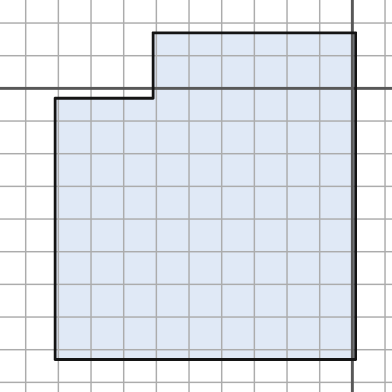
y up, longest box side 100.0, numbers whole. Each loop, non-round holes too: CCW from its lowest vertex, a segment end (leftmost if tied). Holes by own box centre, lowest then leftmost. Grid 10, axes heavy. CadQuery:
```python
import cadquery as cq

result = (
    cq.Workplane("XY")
    .moveTo(-91.0, -83.0)
    .lineTo(1.0, -83.0)
    .lineTo(1.0, 17.0)
    .lineTo(-61.0, 17.0)
    .lineTo(-61.0, -3.0)
    .lineTo(-91.0, -3.0)
    .close()
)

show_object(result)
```